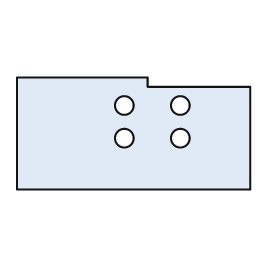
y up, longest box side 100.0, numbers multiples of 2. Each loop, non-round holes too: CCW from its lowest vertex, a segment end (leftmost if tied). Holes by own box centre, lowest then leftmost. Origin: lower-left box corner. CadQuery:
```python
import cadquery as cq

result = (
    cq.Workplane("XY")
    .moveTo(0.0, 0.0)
    .lineTo(100.0, 0.0)
    .lineTo(100.0, 44.0)
    .lineTo(56.0, 44.0)
    .lineTo(56.0, 48.0)
    .lineTo(0.0, 48.0)
    .close()
    .moveTo(46.0, 22.0)
    .circle(4.0)
    .moveTo(70.0, 22.0)
    .circle(4.0)
    .moveTo(46.0, 36.0)
    .circle(4.0)
    .moveTo(70.0, 36.0)
    .circle(4.0)
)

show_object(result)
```